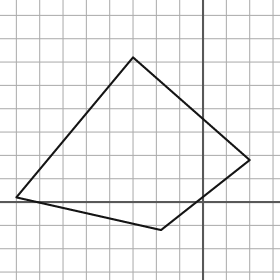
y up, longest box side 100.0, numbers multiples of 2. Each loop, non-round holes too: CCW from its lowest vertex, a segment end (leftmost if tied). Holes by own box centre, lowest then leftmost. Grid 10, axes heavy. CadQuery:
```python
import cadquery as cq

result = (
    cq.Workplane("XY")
    .moveTo(-18.0, -12.0)
    .lineTo(20.0, 18.0)
    .lineTo(-30.0, 62.0)
    .lineTo(-80.0, 2.0)
    .close()
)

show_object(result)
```